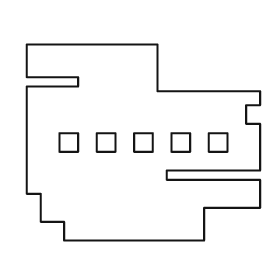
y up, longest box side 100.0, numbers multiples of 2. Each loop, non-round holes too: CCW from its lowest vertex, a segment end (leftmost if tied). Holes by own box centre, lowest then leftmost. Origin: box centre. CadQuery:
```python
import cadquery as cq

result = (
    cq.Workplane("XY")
    .moveTo(-34.0, -42.0)
    .lineTo(26.0, -42.0)
    .lineTo(26.0, -28.0)
    .lineTo(50.0, -28.0)
    .lineTo(50.0, -16.0)
    .lineTo(10.0, -16.0)
    .lineTo(10.0, -12.0)
    .lineTo(50.0, -12.0)
    .lineTo(50.0, 8.0)
    .lineTo(44.0, 8.0)
    .lineTo(44.0, 16.0)
    .lineTo(50.0, 16.0)
    .lineTo(50.0, 22.0)
    .lineTo(6.0, 22.0)
    .lineTo(6.0, 42.0)
    .lineTo(-50.0, 42.0)
    .lineTo(-50.0, 28.0)
    .lineTo(-28.0, 28.0)
    .lineTo(-28.0, 24.0)
    .lineTo(-50.0, 24.0)
    .lineTo(-50.0, -22.0)
    .lineTo(-44.0, -22.0)
    .lineTo(-44.0, -34.0)
    .lineTo(-34.0, -34.0)
    .close()
    .moveTo(-36.0, -4.0)
    .lineTo(-28.0, -4.0)
    .lineTo(-28.0, 4.0)
    .lineTo(-36.0, 4.0)
    .close()
    .moveTo(-20.0, -4.0)
    .lineTo(-12.0, -4.0)
    .lineTo(-12.0, 4.0)
    .lineTo(-20.0, 4.0)
    .close()
    .moveTo(-4.0, -4.0)
    .lineTo(4.0, -4.0)
    .lineTo(4.0, 4.0)
    .lineTo(-4.0, 4.0)
    .close()
    .moveTo(12.0, -4.0)
    .lineTo(20.0, -4.0)
    .lineTo(20.0, 4.0)
    .lineTo(12.0, 4.0)
    .close()
    .moveTo(28.0, -4.0)
    .lineTo(36.0, -4.0)
    .lineTo(36.0, 4.0)
    .lineTo(28.0, 4.0)
    .close()
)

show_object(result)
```